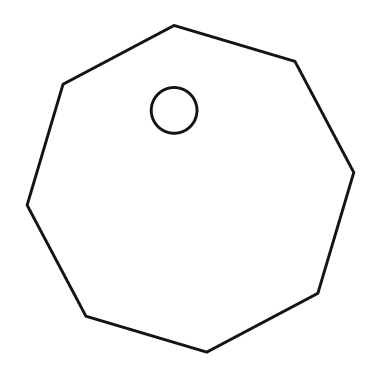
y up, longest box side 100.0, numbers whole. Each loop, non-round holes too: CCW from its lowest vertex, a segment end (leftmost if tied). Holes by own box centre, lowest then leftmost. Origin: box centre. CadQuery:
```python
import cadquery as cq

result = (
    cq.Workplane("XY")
    .moveTo(5.0, -50.0)
    .lineTo(39.0, -32.0)
    .lineTo(50.0, 5.0)
    .lineTo(32.0, 39.0)
    .lineTo(-5.0, 50.0)
    .lineTo(-39.0, 32.0)
    .lineTo(-50.0, -5.0)
    .lineTo(-32.0, -39.0)
    .close()
    .moveTo(-5.0, 24.0)
    .circle(7.0)
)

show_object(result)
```